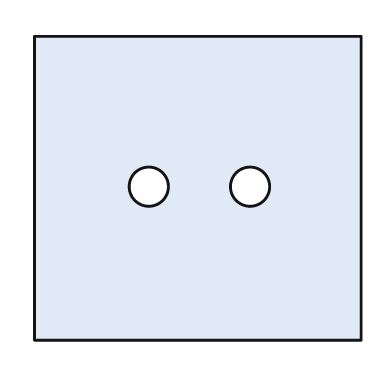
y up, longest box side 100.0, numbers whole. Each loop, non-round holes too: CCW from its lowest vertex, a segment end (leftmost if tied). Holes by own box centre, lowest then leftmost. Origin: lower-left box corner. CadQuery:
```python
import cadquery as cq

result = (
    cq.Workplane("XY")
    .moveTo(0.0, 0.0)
    .lineTo(100.0, 0.0)
    .lineTo(100.0, 93.0)
    .lineTo(0.0, 93.0)
    .close()
    .moveTo(35.0, 47.0)
    .circle(6.0)
    .moveTo(66.0, 47.0)
    .circle(6.0)
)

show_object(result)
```